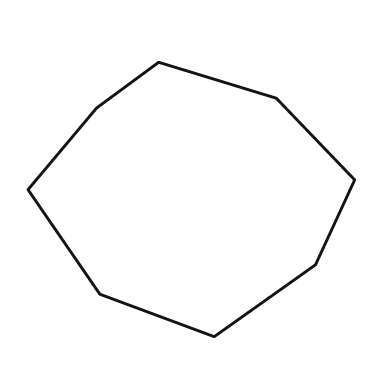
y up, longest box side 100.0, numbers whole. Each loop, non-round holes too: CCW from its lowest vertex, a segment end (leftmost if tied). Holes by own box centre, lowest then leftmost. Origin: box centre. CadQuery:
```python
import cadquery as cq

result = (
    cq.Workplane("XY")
    .moveTo(7.0, -42.0)
    .lineTo(38.0, -20.0)
    .lineTo(50.0, 6.0)
    .lineTo(26.0, 31.0)
    .lineTo(-10.0, 42.0)
    .lineTo(-29.0, 28.0)
    .lineTo(-50.0, 3.0)
    .lineTo(-28.0, -29.0)
    .close()
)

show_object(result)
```